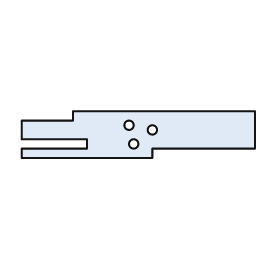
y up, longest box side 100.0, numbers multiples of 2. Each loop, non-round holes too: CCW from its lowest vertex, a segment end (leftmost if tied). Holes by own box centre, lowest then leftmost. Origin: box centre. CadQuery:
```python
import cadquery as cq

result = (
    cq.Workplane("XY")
    .moveTo(-50.0, -10.0)
    .lineTo(6.0, -10.0)
    .lineTo(6.0, -6.0)
    .lineTo(50.0, -6.0)
    .lineTo(50.0, 10.0)
    .lineTo(-28.0, 10.0)
    .lineTo(-28.0, 6.0)
    .lineTo(-50.0, 6.0)
    .lineTo(-50.0, -2.0)
    .lineTo(-22.0, -2.0)
    .lineTo(-22.0, -6.0)
    .lineTo(-50.0, -6.0)
    .close()
    .moveTo(-2.0, -4.0)
    .circle(2.0)
    .moveTo(6.0, 2.0)
    .circle(2.0)
    .moveTo(-4.0, 4.0)
    .circle(2.0)
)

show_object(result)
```